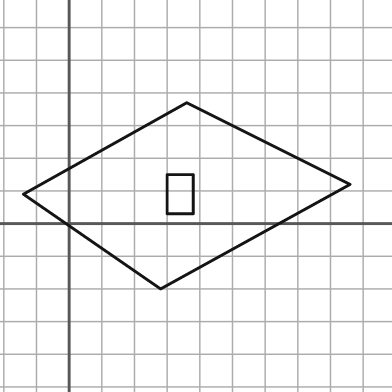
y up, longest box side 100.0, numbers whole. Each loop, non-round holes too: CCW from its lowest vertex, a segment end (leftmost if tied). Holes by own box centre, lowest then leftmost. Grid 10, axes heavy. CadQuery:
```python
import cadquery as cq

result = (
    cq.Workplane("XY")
    .moveTo(28.0, -20.0)
    .lineTo(86.0, 12.0)
    .lineTo(36.0, 37.0)
    .lineTo(-14.0, 9.0)
    .close()
    .moveTo(30.0, 3.0)
    .lineTo(38.0, 3.0)
    .lineTo(38.0, 15.0)
    .lineTo(30.0, 15.0)
    .close()
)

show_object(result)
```